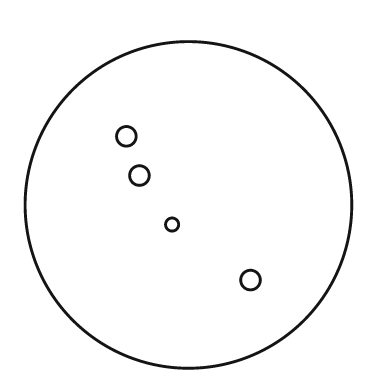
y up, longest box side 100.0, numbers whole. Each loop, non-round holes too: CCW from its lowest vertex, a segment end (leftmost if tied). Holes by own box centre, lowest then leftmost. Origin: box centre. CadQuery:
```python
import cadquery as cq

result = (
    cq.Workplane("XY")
    .moveTo(0.0, 0.0)
    .circle(50.0)
    .moveTo(19.0, -23.0)
    .circle(3.0)
    .moveTo(-5.0, -6.0)
    .circle(2.0)
    .moveTo(-15.0, 9.0)
    .circle(3.0)
    .moveTo(-19.0, 21.0)
    .circle(3.0)
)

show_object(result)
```